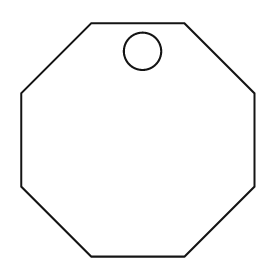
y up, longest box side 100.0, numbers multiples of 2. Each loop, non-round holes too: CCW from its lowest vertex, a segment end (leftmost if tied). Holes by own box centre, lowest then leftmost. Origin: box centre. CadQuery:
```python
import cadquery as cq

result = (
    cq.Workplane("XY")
    .moveTo(-20.0, -50.0)
    .lineTo(20.0, -50.0)
    .lineTo(50.0, -20.0)
    .lineTo(50.0, 20.0)
    .lineTo(20.0, 50.0)
    .lineTo(-20.0, 50.0)
    .lineTo(-50.0, 20.0)
    .lineTo(-50.0, -20.0)
    .close()
    .moveTo(2.0, 38.0)
    .circle(8.0)
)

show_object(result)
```